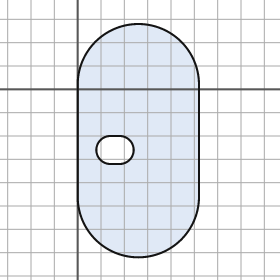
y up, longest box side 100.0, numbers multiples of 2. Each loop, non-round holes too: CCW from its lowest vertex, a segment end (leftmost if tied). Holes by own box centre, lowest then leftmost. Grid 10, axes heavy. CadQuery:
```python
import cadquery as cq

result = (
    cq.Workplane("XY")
    .moveTo(0.0, -46.0)
    .threePointArc((26.0, -72.0), (52.0, -46.0))
    .lineTo(52.0, 2.0)
    .threePointArc((26.0, 28.0), (0.0, 2.0))
    .close()
    .moveTo(14.0, -32.0)
    .lineTo(18.0, -32.0)
    .threePointArc((24.0, -26.0), (18.0, -20.0))
    .lineTo(14.0, -20.0)
    .threePointArc((8.0, -26.0), (14.0, -32.0))
    .close()
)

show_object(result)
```